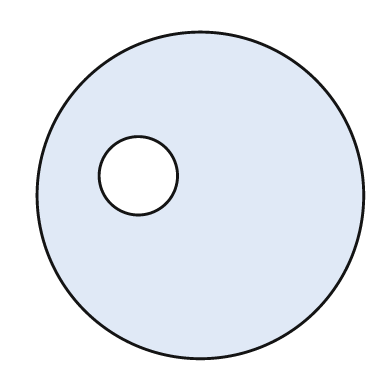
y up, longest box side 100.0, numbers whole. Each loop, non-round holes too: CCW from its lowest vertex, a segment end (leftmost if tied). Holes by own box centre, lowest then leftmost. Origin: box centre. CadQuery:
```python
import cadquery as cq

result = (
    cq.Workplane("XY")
    .moveTo(0.0, 0.0)
    .circle(50.0)
    .moveTo(-19.0, 6.0)
    .circle(12.0)
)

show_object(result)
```